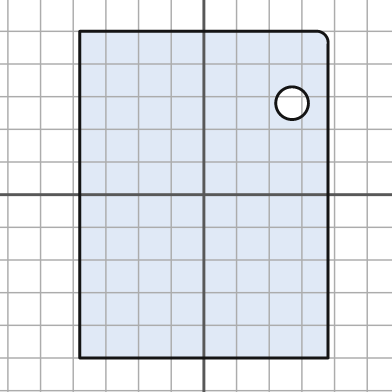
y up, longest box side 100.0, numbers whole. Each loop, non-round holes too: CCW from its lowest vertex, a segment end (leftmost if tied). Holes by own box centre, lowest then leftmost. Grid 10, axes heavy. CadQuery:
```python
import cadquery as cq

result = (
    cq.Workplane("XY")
    .moveTo(-38.0, -50.0)
    .lineTo(38.0, -50.0)
    .lineTo(38.0, 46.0)
    .threePointArc((37.0, 49.0), (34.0, 50.0))
    .lineTo(-38.0, 50.0)
    .close()
    .moveTo(27.0, 28.0)
    .circle(5.0)
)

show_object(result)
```